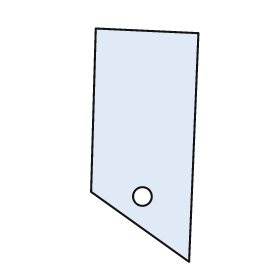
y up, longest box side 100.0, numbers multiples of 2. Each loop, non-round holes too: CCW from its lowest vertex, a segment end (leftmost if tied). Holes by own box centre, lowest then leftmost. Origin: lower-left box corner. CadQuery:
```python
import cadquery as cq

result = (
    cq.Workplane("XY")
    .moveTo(42.0, 0.0)
    .lineTo(46.0, 98.0)
    .lineTo(2.0, 100.0)
    .lineTo(0.0, 30.0)
    .close()
    .moveTo(22.0, 28.0)
    .circle(4.0)
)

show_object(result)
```